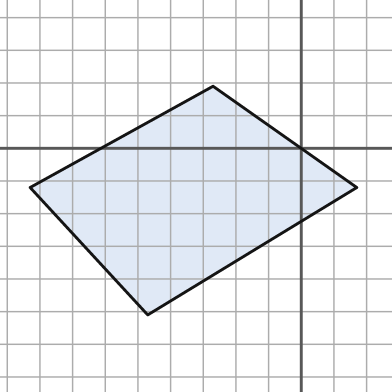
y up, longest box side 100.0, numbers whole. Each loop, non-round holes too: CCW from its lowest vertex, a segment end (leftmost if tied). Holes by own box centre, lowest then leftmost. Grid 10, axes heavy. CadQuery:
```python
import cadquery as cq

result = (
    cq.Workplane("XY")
    .moveTo(-47.0, -51.0)
    .lineTo(17.0, -12.0)
    .lineTo(-27.0, 19.0)
    .lineTo(-83.0, -12.0)
    .close()
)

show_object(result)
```